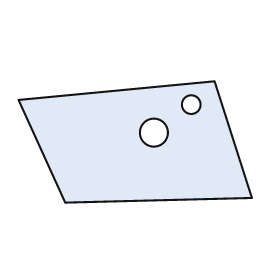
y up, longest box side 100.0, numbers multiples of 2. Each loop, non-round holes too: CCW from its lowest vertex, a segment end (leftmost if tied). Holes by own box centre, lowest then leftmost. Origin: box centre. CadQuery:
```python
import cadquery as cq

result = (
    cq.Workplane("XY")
    .moveTo(-30.0, -26.0)
    .lineTo(50.0, -24.0)
    .lineTo(34.0, 26.0)
    .lineTo(-50.0, 18.0)
    .close()
    .moveTo(8.0, 4.0)
    .circle(6.0)
    .moveTo(24.0, 16.0)
    .circle(4.0)
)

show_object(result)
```